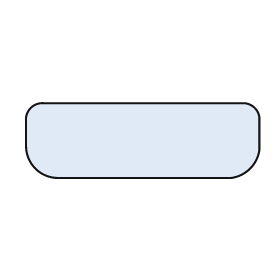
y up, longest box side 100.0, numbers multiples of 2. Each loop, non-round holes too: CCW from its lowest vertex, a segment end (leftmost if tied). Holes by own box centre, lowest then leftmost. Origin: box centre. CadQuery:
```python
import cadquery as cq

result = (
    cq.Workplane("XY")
    .moveTo(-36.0, -16.0)
    .lineTo(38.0, -16.0)
    .threePointArc((46.0, -12.0), (50.0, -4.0))
    .lineTo(50.0, 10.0)
    .threePointArc((48.0, 14.0), (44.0, 16.0))
    .lineTo(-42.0, 16.0)
    .threePointArc((-48.0, 14.0), (-50.0, 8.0))
    .lineTo(-50.0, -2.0)
    .threePointArc((-46.0, -12.0), (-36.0, -16.0))
    .close()
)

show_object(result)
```